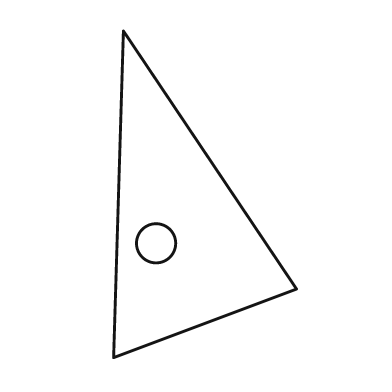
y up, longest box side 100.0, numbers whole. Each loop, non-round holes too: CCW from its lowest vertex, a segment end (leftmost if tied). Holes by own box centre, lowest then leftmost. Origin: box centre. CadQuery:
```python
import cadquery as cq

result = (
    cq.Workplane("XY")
    .moveTo(-28.0, -50.0)
    .lineTo(28.0, -29.0)
    .lineTo(-25.0, 50.0)
    .close()
    .moveTo(-15.0, -15.0)
    .circle(6.0)
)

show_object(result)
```